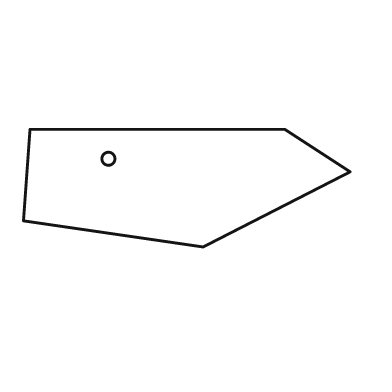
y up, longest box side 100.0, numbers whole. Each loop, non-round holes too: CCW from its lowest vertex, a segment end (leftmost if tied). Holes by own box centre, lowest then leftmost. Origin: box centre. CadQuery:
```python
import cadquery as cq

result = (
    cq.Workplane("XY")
    .moveTo(5.0, -18.0)
    .lineTo(50.0, 5.0)
    .lineTo(30.0, 18.0)
    .lineTo(-48.0, 18.0)
    .lineTo(-50.0, -10.0)
    .close()
    .moveTo(-24.0, 9.0)
    .circle(2.0)
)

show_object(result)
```